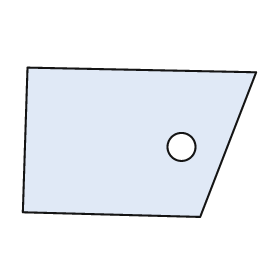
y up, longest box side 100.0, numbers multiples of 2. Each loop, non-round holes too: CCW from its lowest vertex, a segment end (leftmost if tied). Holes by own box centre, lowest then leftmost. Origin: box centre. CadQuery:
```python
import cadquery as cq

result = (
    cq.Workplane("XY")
    .moveTo(26.0, -32.0)
    .lineTo(50.0, 30.0)
    .lineTo(-48.0, 32.0)
    .lineTo(-50.0, -30.0)
    .close()
    .moveTo(18.0, -2.0)
    .circle(6.0)
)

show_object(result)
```